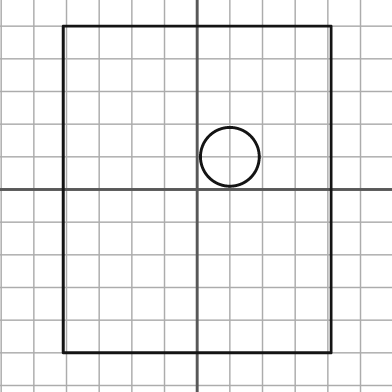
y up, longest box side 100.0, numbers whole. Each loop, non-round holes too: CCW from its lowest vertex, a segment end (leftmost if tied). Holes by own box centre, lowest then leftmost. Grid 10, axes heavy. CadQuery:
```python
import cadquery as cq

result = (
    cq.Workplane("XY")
    .moveTo(-41.0, -50.0)
    .lineTo(41.0, -50.0)
    .lineTo(41.0, 50.0)
    .lineTo(-41.0, 50.0)
    .close()
    .moveTo(10.0, 10.0)
    .circle(9.0)
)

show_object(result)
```